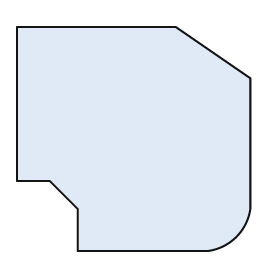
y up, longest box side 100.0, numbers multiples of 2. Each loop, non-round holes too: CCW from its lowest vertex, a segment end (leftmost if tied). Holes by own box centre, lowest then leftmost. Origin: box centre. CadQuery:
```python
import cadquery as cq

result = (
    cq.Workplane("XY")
    .moveTo(-24.0, -48.0)
    .lineTo(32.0, -48.0)
    .threePointArc((44.0, -42.0), (50.0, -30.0))
    .lineTo(50.0, 26.0)
    .lineTo(18.0, 48.0)
    .lineTo(-50.0, 48.0)
    .lineTo(-50.0, -18.0)
    .lineTo(-36.0, -18.0)
    .lineTo(-24.0, -30.0)
    .close()
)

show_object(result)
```